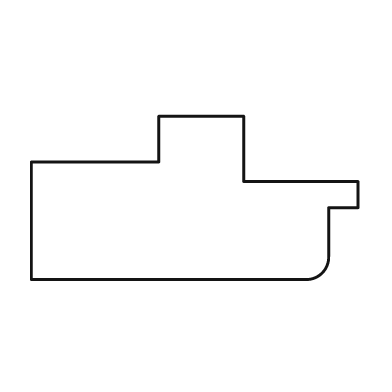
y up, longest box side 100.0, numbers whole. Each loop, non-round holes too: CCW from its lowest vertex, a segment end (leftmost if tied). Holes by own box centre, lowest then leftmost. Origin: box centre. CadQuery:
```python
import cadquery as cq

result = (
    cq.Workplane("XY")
    .moveTo(-50.0, -25.0)
    .lineTo(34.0, -25.0)
    .threePointArc((39.0, -23.0), (41.0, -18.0))
    .lineTo(41.0, -3.0)
    .lineTo(50.0, -3.0)
    .lineTo(50.0, 5.0)
    .lineTo(15.0, 5.0)
    .lineTo(15.0, 25.0)
    .lineTo(-11.0, 25.0)
    .lineTo(-11.0, 11.0)
    .lineTo(-50.0, 11.0)
    .close()
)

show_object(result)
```